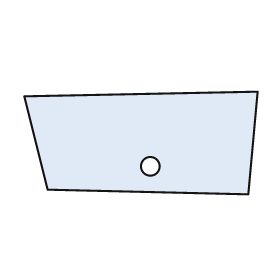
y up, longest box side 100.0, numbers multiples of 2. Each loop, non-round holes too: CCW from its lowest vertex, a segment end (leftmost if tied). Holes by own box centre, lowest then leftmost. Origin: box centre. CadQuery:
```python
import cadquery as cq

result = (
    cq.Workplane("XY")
    .moveTo(46.0, -22.0)
    .lineTo(50.0, 22.0)
    .lineTo(-50.0, 20.0)
    .lineTo(-40.0, -20.0)
    .close()
    .moveTo(4.0, -10.0)
    .circle(4.0)
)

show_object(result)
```